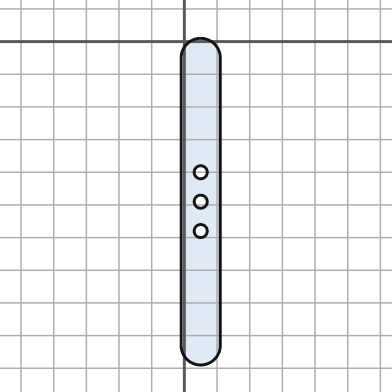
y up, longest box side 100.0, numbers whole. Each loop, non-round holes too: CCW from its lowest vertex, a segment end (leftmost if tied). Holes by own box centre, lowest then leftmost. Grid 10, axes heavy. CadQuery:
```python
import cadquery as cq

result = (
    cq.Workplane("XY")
    .moveTo(-1.0, -93.0)
    .threePointArc((5.0, -99.0), (11.0, -93.0))
    .lineTo(11.0, -5.0)
    .threePointArc((5.0, 1.0), (-1.0, -5.0))
    .close()
    .moveTo(5.0, -58.0)
    .circle(2.0)
    .moveTo(5.0, -49.0)
    .circle(2.0)
    .moveTo(5.0, -40.0)
    .circle(2.0)
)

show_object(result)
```